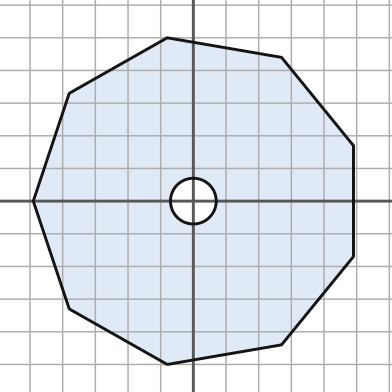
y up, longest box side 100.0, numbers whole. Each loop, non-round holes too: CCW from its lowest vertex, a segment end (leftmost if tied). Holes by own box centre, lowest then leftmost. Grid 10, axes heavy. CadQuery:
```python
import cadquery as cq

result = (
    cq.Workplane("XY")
    .moveTo(-8.0, -50.0)
    .lineTo(27.0, -44.0)
    .lineTo(49.0, -17.0)
    .lineTo(49.0, 17.0)
    .lineTo(27.0, 44.0)
    .lineTo(-8.0, 50.0)
    .lineTo(-38.0, 33.0)
    .lineTo(-49.0, 0.0)
    .lineTo(-38.0, -33.0)
    .close()
    .moveTo(0.0, 0.0)
    .circle(7.0)
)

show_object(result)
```